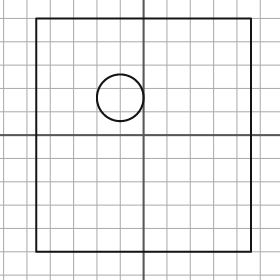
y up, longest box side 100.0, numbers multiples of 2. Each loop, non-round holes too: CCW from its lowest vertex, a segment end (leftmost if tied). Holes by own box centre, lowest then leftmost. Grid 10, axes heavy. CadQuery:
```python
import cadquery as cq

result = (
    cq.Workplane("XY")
    .moveTo(-46.0, -50.0)
    .lineTo(46.0, -50.0)
    .lineTo(46.0, 50.0)
    .lineTo(-46.0, 50.0)
    .close()
    .moveTo(-10.0, 16.0)
    .circle(10.0)
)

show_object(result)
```